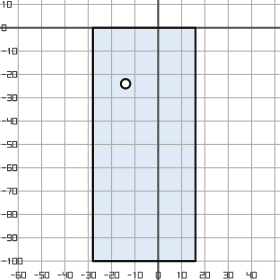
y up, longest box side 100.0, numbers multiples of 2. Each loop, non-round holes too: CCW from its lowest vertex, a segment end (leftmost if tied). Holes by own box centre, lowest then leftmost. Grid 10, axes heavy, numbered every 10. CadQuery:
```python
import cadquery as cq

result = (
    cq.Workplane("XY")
    .moveTo(-28.0, -100.0)
    .lineTo(16.0, -100.0)
    .lineTo(16.0, 0.0)
    .lineTo(-28.0, 0.0)
    .close()
    .moveTo(-14.0, -24.0)
    .circle(2.0)
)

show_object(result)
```